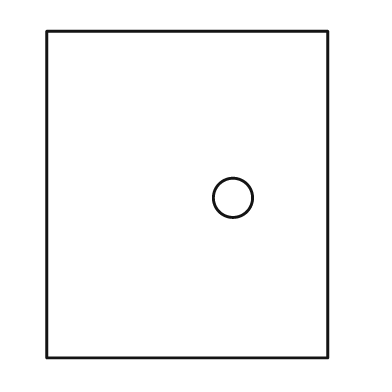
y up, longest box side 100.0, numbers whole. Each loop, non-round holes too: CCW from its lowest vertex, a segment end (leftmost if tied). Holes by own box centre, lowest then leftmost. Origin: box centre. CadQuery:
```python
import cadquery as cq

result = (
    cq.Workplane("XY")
    .moveTo(-43.0, -50.0)
    .lineTo(43.0, -50.0)
    .lineTo(43.0, 50.0)
    .lineTo(-43.0, 50.0)
    .close()
    .moveTo(14.0, -1.0)
    .circle(6.0)
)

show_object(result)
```